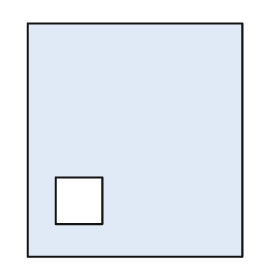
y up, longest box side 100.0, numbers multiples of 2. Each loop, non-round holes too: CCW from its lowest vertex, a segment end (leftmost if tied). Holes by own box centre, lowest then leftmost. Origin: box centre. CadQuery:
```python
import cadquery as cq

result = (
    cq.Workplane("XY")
    .moveTo(-46.0, -50.0)
    .lineTo(46.0, -50.0)
    .lineTo(46.0, 50.0)
    .lineTo(-46.0, 50.0)
    .close()
    .moveTo(-34.0, -36.0)
    .lineTo(-14.0, -36.0)
    .lineTo(-14.0, -16.0)
    .lineTo(-34.0, -16.0)
    .close()
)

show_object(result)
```